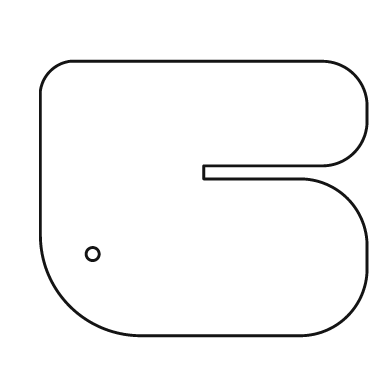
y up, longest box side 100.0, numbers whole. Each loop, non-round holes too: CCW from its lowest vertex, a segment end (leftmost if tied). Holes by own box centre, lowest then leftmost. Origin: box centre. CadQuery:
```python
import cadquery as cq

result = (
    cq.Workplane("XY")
    .moveTo(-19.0, -42.0)
    .lineTo(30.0, -42.0)
    .threePointArc((44.0, -36.0), (50.0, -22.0))
    .lineTo(50.0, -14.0)
    .threePointArc((44.0, 0.0), (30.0, 6.0))
    .lineTo(0.0, 6.0)
    .lineTo(0.0, 10.0)
    .lineTo(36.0, 10.0)
    .threePointArc((46.0, 14.0), (50.0, 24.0))
    .lineTo(50.0, 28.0)
    .threePointArc((46.0, 38.0), (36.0, 42.0))
    .lineTo(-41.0, 42.0)
    .threePointArc((-47.0, 39.0), (-50.0, 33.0))
    .lineTo(-50.0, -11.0)
    .threePointArc((-41.0, -33.0), (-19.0, -42.0))
    .close()
    .moveTo(-34.0, -17.0)
    .circle(2.0)
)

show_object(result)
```